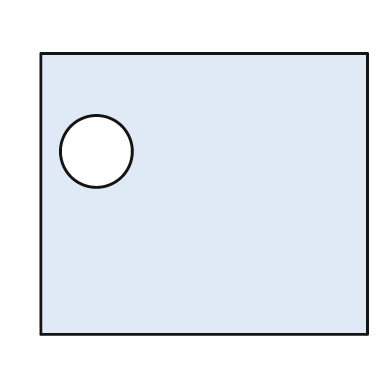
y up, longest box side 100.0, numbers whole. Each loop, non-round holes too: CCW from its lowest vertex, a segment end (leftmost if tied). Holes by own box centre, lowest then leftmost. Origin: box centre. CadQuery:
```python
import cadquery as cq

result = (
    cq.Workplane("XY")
    .moveTo(-50.0, -43.0)
    .lineTo(50.0, -43.0)
    .lineTo(50.0, 43.0)
    .lineTo(-50.0, 43.0)
    .close()
    .moveTo(-33.0, 13.0)
    .circle(11.0)
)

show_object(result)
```